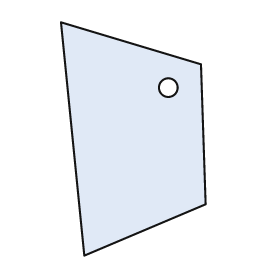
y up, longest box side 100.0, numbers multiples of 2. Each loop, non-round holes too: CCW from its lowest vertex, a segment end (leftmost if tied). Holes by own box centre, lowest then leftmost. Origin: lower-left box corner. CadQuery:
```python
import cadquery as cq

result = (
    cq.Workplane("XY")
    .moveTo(10.0, 0.0)
    .lineTo(62.0, 22.0)
    .lineTo(60.0, 82.0)
    .lineTo(0.0, 100.0)
    .close()
    .moveTo(46.0, 72.0)
    .circle(4.0)
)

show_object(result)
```